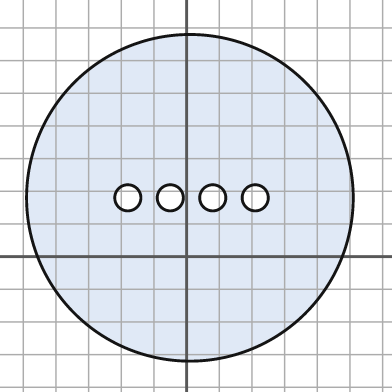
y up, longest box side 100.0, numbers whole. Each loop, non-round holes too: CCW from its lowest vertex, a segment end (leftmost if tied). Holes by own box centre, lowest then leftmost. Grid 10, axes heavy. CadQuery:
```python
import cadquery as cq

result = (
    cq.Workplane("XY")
    .moveTo(1.0, 18.0)
    .circle(50.0)
    .moveTo(-18.0, 18.0)
    .circle(4.0)
    .moveTo(-5.0, 18.0)
    .circle(4.0)
    .moveTo(8.0, 18.0)
    .circle(4.0)
    .moveTo(21.0, 18.0)
    .circle(4.0)
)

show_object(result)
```